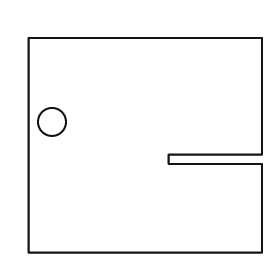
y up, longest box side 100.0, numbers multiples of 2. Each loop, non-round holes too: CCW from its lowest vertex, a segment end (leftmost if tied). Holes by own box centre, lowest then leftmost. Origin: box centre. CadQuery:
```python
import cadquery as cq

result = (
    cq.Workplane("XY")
    .moveTo(-50.0, -46.0)
    .lineTo(50.0, -46.0)
    .lineTo(50.0, -8.0)
    .lineTo(10.0, -8.0)
    .lineTo(10.0, -4.0)
    .lineTo(50.0, -4.0)
    .lineTo(50.0, 46.0)
    .lineTo(-50.0, 46.0)
    .close()
    .moveTo(-40.0, 10.0)
    .circle(6.0)
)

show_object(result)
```